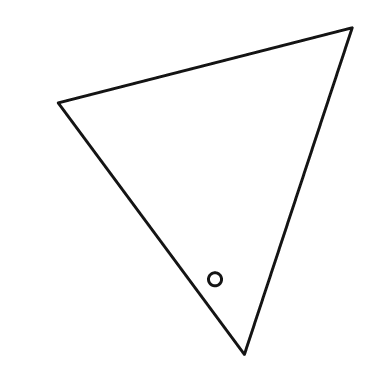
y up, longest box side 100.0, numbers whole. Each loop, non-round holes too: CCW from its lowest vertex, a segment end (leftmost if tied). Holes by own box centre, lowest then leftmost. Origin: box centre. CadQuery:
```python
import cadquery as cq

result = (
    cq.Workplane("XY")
    .moveTo(12.0, -50.0)
    .lineTo(45.0, 50.0)
    .lineTo(-45.0, 27.0)
    .close()
    .moveTo(3.0, -27.0)
    .circle(2.0)
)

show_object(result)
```